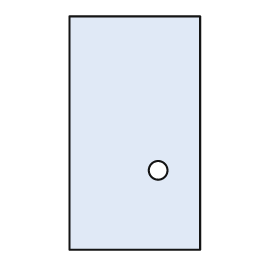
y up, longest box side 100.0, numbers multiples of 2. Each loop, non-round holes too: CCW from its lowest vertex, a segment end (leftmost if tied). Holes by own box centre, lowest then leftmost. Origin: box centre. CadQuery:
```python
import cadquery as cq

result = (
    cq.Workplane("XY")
    .moveTo(-28.0, -50.0)
    .lineTo(28.0, -50.0)
    .lineTo(28.0, 50.0)
    .lineTo(-28.0, 50.0)
    .close()
    .moveTo(10.0, -16.0)
    .circle(4.0)
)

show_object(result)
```